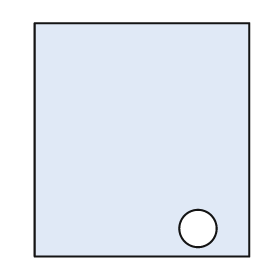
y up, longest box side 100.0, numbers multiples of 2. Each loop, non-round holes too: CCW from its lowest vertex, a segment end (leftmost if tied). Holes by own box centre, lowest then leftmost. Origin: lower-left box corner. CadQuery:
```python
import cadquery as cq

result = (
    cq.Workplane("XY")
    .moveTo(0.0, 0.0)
    .lineTo(92.0, 0.0)
    .lineTo(92.0, 100.0)
    .lineTo(0.0, 100.0)
    .close()
    .moveTo(70.0, 12.0)
    .circle(8.0)
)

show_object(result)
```